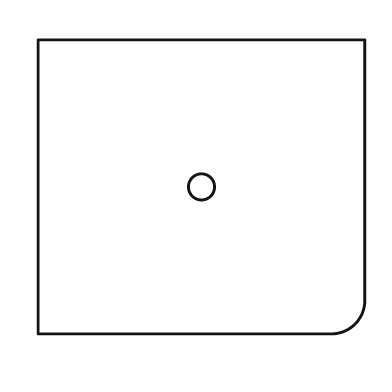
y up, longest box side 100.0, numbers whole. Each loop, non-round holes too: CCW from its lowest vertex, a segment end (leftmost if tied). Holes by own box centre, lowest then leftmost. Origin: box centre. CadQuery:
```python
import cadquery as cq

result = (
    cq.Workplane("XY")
    .moveTo(-50.0, -45.0)
    .lineTo(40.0, -45.0)
    .threePointArc((47.0, -42.0), (50.0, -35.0))
    .lineTo(50.0, 45.0)
    .lineTo(-50.0, 45.0)
    .close()
    .moveTo(0.0, 0.0)
    .circle(4.0)
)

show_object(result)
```